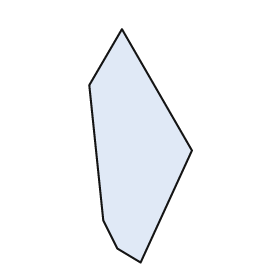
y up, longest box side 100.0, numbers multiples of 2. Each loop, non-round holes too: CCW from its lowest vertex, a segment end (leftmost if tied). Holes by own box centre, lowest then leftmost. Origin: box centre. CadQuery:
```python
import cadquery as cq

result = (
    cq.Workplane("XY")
    .moveTo(0.0, -50.0)
    .lineTo(22.0, -2.0)
    .lineTo(-8.0, 50.0)
    .lineTo(-22.0, 26.0)
    .lineTo(-16.0, -32.0)
    .lineTo(-10.0, -44.0)
    .close()
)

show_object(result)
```